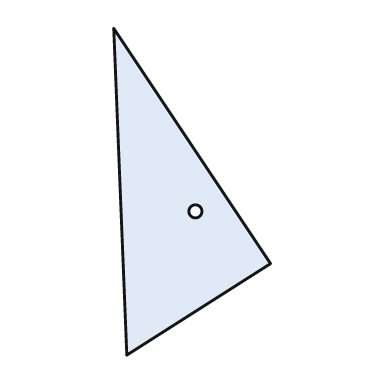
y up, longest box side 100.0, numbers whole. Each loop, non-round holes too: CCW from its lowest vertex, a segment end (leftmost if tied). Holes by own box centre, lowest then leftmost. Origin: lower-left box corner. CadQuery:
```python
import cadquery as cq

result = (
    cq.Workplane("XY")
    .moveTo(4.0, 0.0)
    .lineTo(48.0, 28.0)
    .lineTo(0.0, 100.0)
    .close()
    .moveTo(25.0, 44.0)
    .circle(2.0)
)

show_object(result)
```